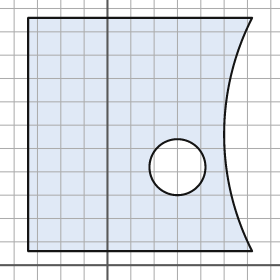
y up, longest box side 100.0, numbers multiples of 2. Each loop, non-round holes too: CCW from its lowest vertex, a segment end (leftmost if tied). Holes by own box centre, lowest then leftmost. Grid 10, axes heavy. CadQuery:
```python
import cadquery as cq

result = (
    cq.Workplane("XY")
    .moveTo(-34.0, 6.0)
    .lineTo(62.0, 6.0)
    .threePointArc((50.0, 56.0), (62.0, 106.0))
    .lineTo(-34.0, 106.0)
    .close()
    .moveTo(30.0, 42.0)
    .circle(12.0)
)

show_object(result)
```